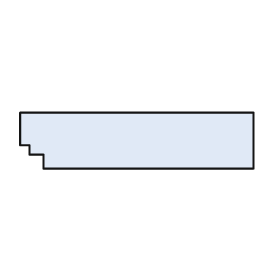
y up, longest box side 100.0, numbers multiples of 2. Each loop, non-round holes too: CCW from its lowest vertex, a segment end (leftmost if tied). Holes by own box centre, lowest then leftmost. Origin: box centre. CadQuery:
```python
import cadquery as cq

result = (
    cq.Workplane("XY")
    .moveTo(-40.0, -12.0)
    .lineTo(50.0, -12.0)
    .lineTo(50.0, 12.0)
    .lineTo(-50.0, 12.0)
    .lineTo(-50.0, -2.0)
    .lineTo(-46.0, -2.0)
    .lineTo(-46.0, -6.0)
    .lineTo(-40.0, -6.0)
    .close()
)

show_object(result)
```